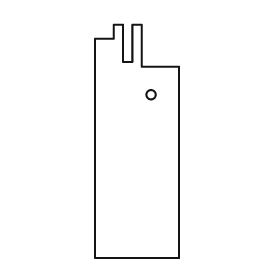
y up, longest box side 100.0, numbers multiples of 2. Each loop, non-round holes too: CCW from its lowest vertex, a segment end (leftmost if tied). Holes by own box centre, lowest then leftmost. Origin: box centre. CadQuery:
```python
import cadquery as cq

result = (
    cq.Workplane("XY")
    .moveTo(-18.0, -50.0)
    .lineTo(18.0, -50.0)
    .lineTo(18.0, 32.0)
    .lineTo(2.0, 32.0)
    .lineTo(2.0, 50.0)
    .lineTo(-2.0, 50.0)
    .lineTo(-2.0, 34.0)
    .lineTo(-6.0, 34.0)
    .lineTo(-6.0, 50.0)
    .lineTo(-10.0, 50.0)
    .lineTo(-10.0, 44.0)
    .lineTo(-18.0, 44.0)
    .close()
    .moveTo(6.0, 20.0)
    .circle(2.0)
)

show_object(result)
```